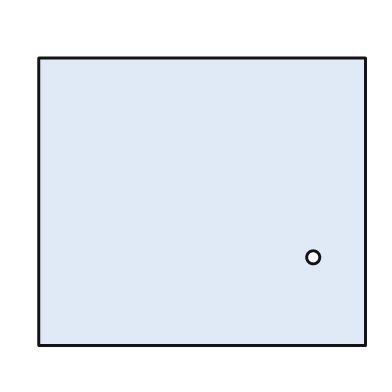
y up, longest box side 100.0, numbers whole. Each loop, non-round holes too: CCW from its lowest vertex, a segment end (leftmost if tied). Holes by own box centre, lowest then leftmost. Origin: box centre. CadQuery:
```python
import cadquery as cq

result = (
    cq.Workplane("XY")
    .moveTo(-50.0, -44.0)
    .lineTo(50.0, -44.0)
    .lineTo(50.0, 44.0)
    .lineTo(-50.0, 44.0)
    .close()
    .moveTo(34.0, -17.0)
    .circle(2.0)
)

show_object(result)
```